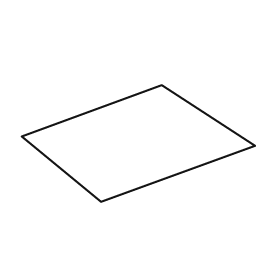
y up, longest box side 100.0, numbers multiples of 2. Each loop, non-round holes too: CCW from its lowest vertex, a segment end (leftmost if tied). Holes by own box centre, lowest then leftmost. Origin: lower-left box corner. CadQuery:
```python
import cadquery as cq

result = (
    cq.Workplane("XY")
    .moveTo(34.0, 0.0)
    .lineTo(100.0, 24.0)
    .lineTo(60.0, 50.0)
    .lineTo(0.0, 28.0)
    .close()
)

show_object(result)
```